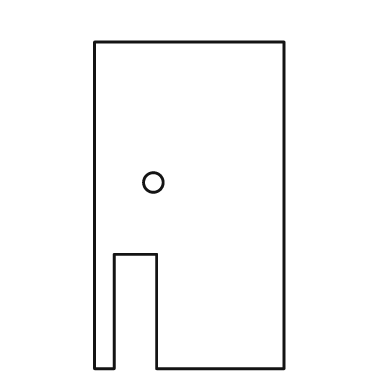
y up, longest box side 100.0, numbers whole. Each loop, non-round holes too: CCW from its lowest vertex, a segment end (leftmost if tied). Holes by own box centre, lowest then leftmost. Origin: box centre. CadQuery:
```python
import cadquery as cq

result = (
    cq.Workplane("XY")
    .moveTo(-29.0, -50.0)
    .lineTo(-23.0, -50.0)
    .lineTo(-23.0, -15.0)
    .lineTo(-10.0, -15.0)
    .lineTo(-10.0, -50.0)
    .lineTo(29.0, -50.0)
    .lineTo(29.0, 50.0)
    .lineTo(-29.0, 50.0)
    .close()
    .moveTo(-11.0, 7.0)
    .circle(3.0)
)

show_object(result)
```